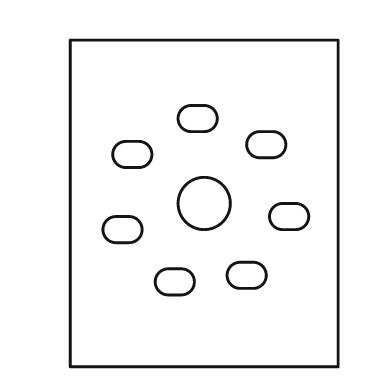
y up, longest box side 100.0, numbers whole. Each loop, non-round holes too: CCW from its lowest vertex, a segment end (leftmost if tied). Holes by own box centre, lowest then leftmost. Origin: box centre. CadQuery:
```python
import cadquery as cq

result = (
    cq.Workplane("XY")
    .moveTo(-41.0, -50.0)
    .lineTo(41.0, -50.0)
    .lineTo(41.0, 50.0)
    .lineTo(-41.0, 50.0)
    .close()
    .moveTo(-11.0, -28.0)
    .lineTo(-7.0, -28.0)
    .threePointArc((-3.0, -24.0), (-7.0, -20.0))
    .lineTo(-11.0, -20.0)
    .threePointArc((-15.0, -24.0), (-11.0, -28.0))
    .close()
    .moveTo(11.0, -26.0)
    .lineTo(15.0, -26.0)
    .threePointArc((19.0, -22.0), (15.0, -18.0))
    .lineTo(11.0, -18.0)
    .threePointArc((7.0, -22.0), (11.0, -26.0))
    .close()
    .moveTo(-27.0, -12.0)
    .lineTo(-23.0, -12.0)
    .threePointArc((-19.0, -8.0), (-23.0, -4.0))
    .lineTo(-27.0, -4.0)
    .threePointArc((-31.0, -8.0), (-27.0, -12.0))
    .close()
    .moveTo(24.0, -8.0)
    .lineTo(28.0, -8.0)
    .threePointArc((32.0, -4.0), (28.0, 0.0))
    .lineTo(24.0, 0.0)
    .threePointArc((20.0, -4.0), (24.0, -8.0))
    .close()
    .moveTo(0.0, 0.0)
    .circle(8.0)
    .moveTo(-24.0, 11.0)
    .lineTo(-20.0, 11.0)
    .threePointArc((-16.0, 15.0), (-20.0, 19.0))
    .lineTo(-24.0, 19.0)
    .threePointArc((-28.0, 15.0), (-24.0, 11.0))
    .close()
    .moveTo(17.0, 14.0)
    .lineTo(21.0, 14.0)
    .threePointArc((25.0, 18.0), (21.0, 22.0))
    .lineTo(17.0, 22.0)
    .threePointArc((13.0, 18.0), (17.0, 14.0))
    .close()
    .moveTo(-4.0, 22.0)
    .lineTo(0.0, 22.0)
    .threePointArc((4.0, 26.0), (0.0, 30.0))
    .lineTo(-4.0, 30.0)
    .threePointArc((-8.0, 26.0), (-4.0, 22.0))
    .close()
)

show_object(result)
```